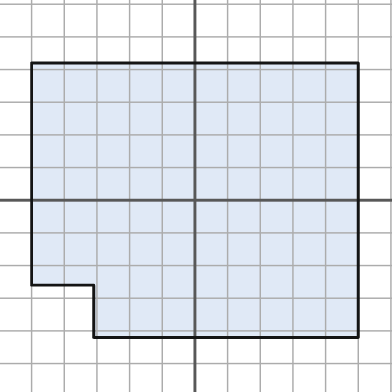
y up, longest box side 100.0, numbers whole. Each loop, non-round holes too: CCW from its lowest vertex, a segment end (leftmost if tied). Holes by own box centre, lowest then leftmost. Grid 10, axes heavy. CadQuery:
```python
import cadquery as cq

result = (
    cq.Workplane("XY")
    .moveTo(-31.0, -42.0)
    .lineTo(50.0, -42.0)
    .lineTo(50.0, 42.0)
    .lineTo(-50.0, 42.0)
    .lineTo(-50.0, -26.0)
    .lineTo(-31.0, -26.0)
    .close()
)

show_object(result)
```